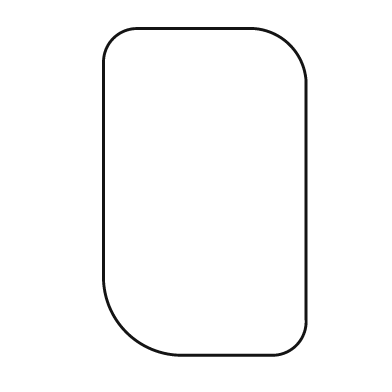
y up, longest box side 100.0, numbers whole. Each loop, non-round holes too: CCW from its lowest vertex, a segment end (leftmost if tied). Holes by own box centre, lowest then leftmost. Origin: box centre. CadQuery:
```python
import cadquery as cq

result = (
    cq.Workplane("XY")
    .moveTo(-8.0, -50.0)
    .lineTo(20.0, -50.0)
    .threePointArc((28.0, -47.0), (31.0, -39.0))
    .lineTo(31.0, 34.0)
    .threePointArc((26.0, 45.0), (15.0, 50.0))
    .lineTo(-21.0, 50.0)
    .threePointArc((-28.0, 47.0), (-31.0, 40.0))
    .lineTo(-31.0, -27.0)
    .threePointArc((-24.0, -43.0), (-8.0, -50.0))
    .close()
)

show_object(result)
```